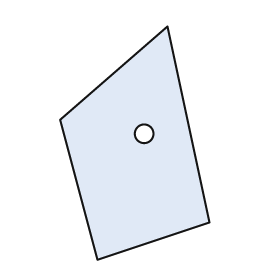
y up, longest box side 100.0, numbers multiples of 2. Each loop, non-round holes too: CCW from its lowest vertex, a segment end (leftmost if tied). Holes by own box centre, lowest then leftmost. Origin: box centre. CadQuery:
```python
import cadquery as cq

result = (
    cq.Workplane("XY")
    .moveTo(-16.0, -50.0)
    .lineTo(32.0, -34.0)
    .lineTo(14.0, 50.0)
    .lineTo(-32.0, 10.0)
    .close()
    .moveTo(4.0, 4.0)
    .circle(4.0)
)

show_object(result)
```